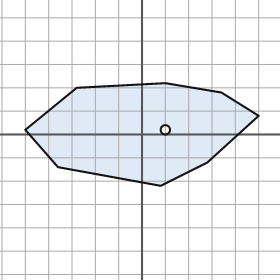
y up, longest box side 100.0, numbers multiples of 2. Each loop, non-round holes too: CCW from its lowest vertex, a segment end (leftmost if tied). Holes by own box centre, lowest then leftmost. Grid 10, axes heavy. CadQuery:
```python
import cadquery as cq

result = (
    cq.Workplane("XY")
    .moveTo(8.0, -22.0)
    .lineTo(28.0, -12.0)
    .lineTo(50.0, 8.0)
    .lineTo(34.0, 18.0)
    .lineTo(10.0, 22.0)
    .lineTo(-28.0, 20.0)
    .lineTo(-50.0, 2.0)
    .lineTo(-36.0, -14.0)
    .close()
    .moveTo(10.0, 2.0)
    .circle(2.0)
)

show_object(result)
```